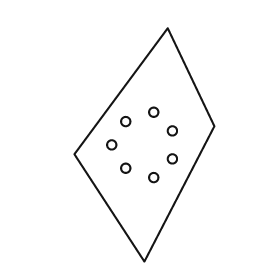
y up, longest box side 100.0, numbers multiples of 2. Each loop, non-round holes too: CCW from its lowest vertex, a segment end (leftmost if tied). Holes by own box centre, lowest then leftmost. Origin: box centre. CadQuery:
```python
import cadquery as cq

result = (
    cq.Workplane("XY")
    .moveTo(0.0, -50.0)
    .lineTo(30.0, 8.0)
    .lineTo(10.0, 50.0)
    .lineTo(-30.0, -4.0)
    .close()
    .moveTo(4.0, -14.0)
    .circle(2.0)
    .moveTo(-8.0, -10.0)
    .circle(2.0)
    .moveTo(12.0, -6.0)
    .circle(2.0)
    .moveTo(-14.0, 0.0)
    .circle(2.0)
    .moveTo(12.0, 6.0)
    .circle(2.0)
    .moveTo(-8.0, 10.0)
    .circle(2.0)
    .moveTo(4.0, 14.0)
    .circle(2.0)
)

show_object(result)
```